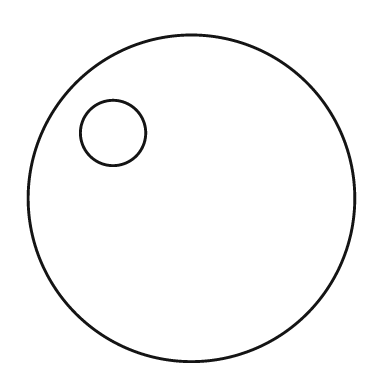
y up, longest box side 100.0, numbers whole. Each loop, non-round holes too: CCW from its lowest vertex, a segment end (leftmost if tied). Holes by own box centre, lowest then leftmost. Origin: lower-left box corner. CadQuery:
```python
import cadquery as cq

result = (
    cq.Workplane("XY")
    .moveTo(50.0, 50.0)
    .circle(50.0)
    .moveTo(26.0, 70.0)
    .circle(10.0)
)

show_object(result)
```